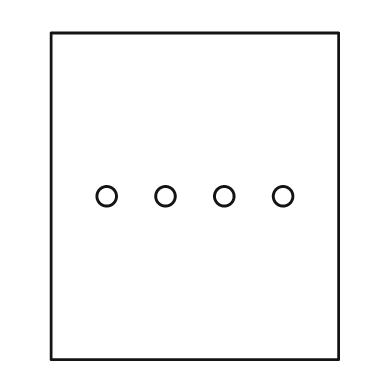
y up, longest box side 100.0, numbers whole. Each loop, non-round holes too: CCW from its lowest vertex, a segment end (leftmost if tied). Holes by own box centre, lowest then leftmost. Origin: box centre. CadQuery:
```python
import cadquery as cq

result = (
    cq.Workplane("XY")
    .moveTo(-44.0, -50.0)
    .lineTo(44.0, -50.0)
    .lineTo(44.0, 50.0)
    .lineTo(-44.0, 50.0)
    .close()
    .moveTo(-27.0, 0.0)
    .circle(3.0)
    .moveTo(-9.0, 0.0)
    .circle(3.0)
    .moveTo(9.0, 0.0)
    .circle(3.0)
    .moveTo(27.0, 0.0)
    .circle(3.0)
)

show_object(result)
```